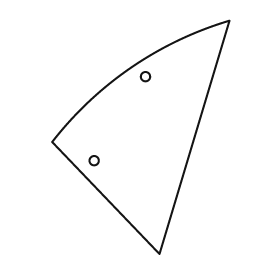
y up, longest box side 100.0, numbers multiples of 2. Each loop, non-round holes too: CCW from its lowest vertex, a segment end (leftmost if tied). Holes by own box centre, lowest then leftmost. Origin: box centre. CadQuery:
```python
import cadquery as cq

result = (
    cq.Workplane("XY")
    .moveTo(8.0, -50.0)
    .lineTo(38.0, 50.0)
    .threePointArc((-4.0, 30.0), (-38.0, -2.0))
    .close()
    .moveTo(-20.0, -10.0)
    .circle(2.0)
    .moveTo(2.0, 26.0)
    .circle(2.0)
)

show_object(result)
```